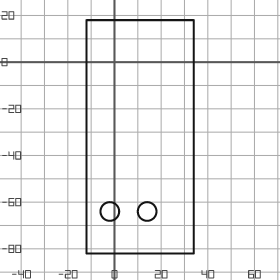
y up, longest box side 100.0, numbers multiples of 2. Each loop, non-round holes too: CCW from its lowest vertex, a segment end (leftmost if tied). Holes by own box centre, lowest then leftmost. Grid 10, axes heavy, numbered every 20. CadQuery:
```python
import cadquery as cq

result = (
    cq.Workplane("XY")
    .moveTo(-12.0, -82.0)
    .lineTo(34.0, -82.0)
    .lineTo(34.0, 18.0)
    .lineTo(-12.0, 18.0)
    .close()
    .moveTo(-2.0, -64.0)
    .circle(4.0)
    .moveTo(14.0, -64.0)
    .circle(4.0)
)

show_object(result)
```